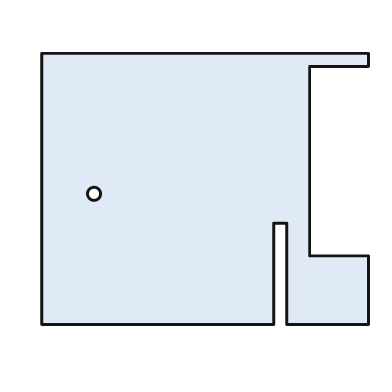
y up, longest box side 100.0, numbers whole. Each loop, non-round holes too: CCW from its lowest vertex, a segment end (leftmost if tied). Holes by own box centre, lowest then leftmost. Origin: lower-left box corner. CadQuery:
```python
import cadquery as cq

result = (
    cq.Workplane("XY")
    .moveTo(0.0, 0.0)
    .lineTo(71.0, 0.0)
    .lineTo(71.0, 31.0)
    .lineTo(75.0, 31.0)
    .lineTo(75.0, 0.0)
    .lineTo(100.0, 0.0)
    .lineTo(100.0, 21.0)
    .lineTo(82.0, 21.0)
    .lineTo(82.0, 79.0)
    .lineTo(100.0, 79.0)
    .lineTo(100.0, 83.0)
    .lineTo(0.0, 83.0)
    .close()
    .moveTo(16.0, 40.0)
    .circle(2.0)
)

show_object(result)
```